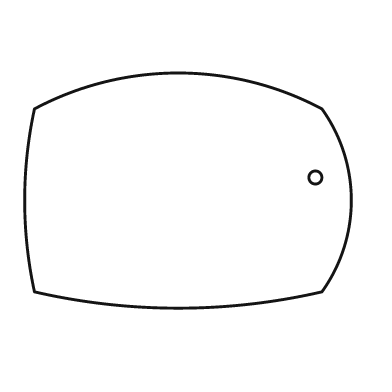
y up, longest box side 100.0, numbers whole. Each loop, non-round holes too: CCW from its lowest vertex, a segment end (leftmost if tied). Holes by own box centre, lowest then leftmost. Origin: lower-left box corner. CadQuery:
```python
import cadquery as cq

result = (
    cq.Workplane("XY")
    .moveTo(3.0, 5.0)
    .threePointArc((47.0, 0.0), (91.0, 5.0))
    .threePointArc((100.0, 33.0), (91.0, 61.0))
    .threePointArc((47.0, 72.0), (3.0, 61.0))
    .threePointArc((0.0, 33.0), (3.0, 5.0))
    .close()
    .moveTo(89.0, 40.0)
    .circle(2.0)
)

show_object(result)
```